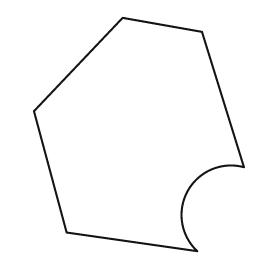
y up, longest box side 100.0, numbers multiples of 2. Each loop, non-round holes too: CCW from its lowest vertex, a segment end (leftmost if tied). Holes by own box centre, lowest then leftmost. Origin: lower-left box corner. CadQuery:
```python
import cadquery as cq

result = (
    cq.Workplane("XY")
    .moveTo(70.0, 0.0)
    .threePointArc((66.0, 26.0), (90.0, 36.0))
    .lineTo(72.0, 94.0)
    .lineTo(38.0, 100.0)
    .lineTo(0.0, 60.0)
    .lineTo(14.0, 8.0)
    .close()
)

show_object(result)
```